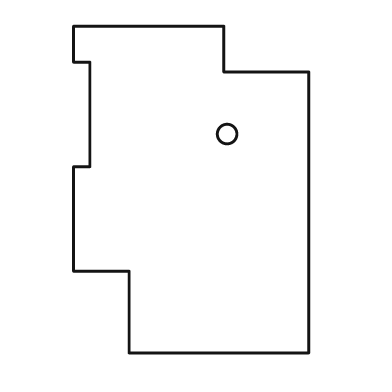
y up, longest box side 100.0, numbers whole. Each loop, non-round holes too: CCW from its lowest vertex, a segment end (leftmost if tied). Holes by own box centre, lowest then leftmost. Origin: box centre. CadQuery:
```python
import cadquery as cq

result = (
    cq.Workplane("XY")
    .moveTo(-19.0, -50.0)
    .lineTo(36.0, -50.0)
    .lineTo(36.0, 36.0)
    .lineTo(10.0, 36.0)
    .lineTo(10.0, 50.0)
    .lineTo(-36.0, 50.0)
    .lineTo(-36.0, 39.0)
    .lineTo(-31.0, 39.0)
    .lineTo(-31.0, 7.0)
    .lineTo(-36.0, 7.0)
    .lineTo(-36.0, -25.0)
    .lineTo(-19.0, -25.0)
    .close()
    .moveTo(11.0, 17.0)
    .circle(3.0)
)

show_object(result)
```